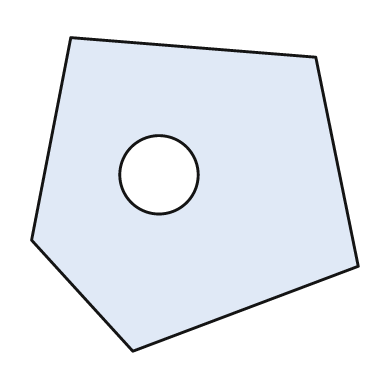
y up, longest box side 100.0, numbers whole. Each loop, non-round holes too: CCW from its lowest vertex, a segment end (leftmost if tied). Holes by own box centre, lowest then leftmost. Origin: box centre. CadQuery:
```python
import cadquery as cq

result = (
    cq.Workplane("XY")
    .moveTo(-19.0, -48.0)
    .lineTo(50.0, -22.0)
    .lineTo(37.0, 42.0)
    .lineTo(-38.0, 48.0)
    .lineTo(-50.0, -14.0)
    .close()
    .moveTo(-11.0, 6.0)
    .circle(12.0)
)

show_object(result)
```